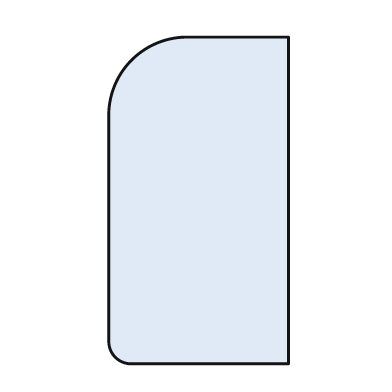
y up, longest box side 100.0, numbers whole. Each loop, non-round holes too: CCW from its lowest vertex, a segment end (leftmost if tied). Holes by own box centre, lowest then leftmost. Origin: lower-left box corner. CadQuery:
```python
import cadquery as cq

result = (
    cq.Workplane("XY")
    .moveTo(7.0, 0.0)
    .lineTo(55.0, 0.0)
    .lineTo(55.0, 100.0)
    .lineTo(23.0, 100.0)
    .threePointArc((7.0, 93.0), (0.0, 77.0))
    .lineTo(0.0, 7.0)
    .threePointArc((2.0, 2.0), (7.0, 0.0))
    .close()
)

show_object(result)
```